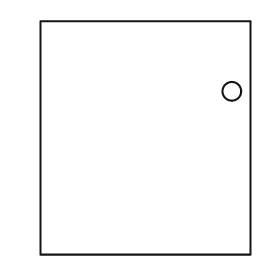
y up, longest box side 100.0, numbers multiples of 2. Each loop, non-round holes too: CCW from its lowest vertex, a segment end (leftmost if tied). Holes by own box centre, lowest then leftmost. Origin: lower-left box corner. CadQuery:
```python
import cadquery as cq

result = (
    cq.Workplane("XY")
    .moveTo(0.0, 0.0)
    .lineTo(90.0, 0.0)
    .lineTo(90.0, 100.0)
    .lineTo(0.0, 100.0)
    .close()
    .moveTo(82.0, 70.0)
    .circle(4.0)
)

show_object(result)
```